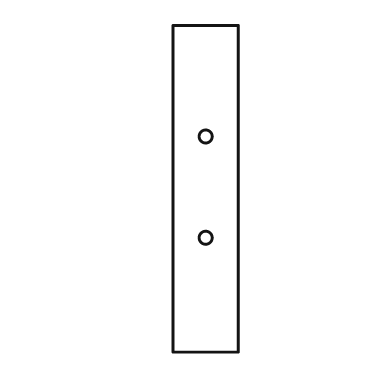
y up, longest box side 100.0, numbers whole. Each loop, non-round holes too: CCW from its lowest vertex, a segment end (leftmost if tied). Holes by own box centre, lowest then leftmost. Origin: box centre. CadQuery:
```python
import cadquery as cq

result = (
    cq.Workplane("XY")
    .moveTo(-10.0, -50.0)
    .lineTo(10.0, -50.0)
    .lineTo(10.0, 50.0)
    .lineTo(-10.0, 50.0)
    .close()
    .moveTo(0.0, -15.0)
    .circle(2.0)
    .moveTo(0.0, 16.0)
    .circle(2.0)
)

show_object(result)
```